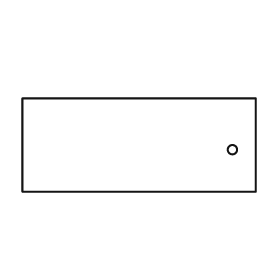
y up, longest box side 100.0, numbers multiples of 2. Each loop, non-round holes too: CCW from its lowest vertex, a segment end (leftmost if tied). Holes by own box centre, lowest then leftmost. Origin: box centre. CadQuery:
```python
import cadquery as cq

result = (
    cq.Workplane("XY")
    .moveTo(-50.0, -20.0)
    .lineTo(50.0, -20.0)
    .lineTo(50.0, 20.0)
    .lineTo(-50.0, 20.0)
    .close()
    .moveTo(40.0, -2.0)
    .circle(2.0)
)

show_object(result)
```